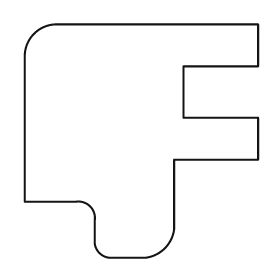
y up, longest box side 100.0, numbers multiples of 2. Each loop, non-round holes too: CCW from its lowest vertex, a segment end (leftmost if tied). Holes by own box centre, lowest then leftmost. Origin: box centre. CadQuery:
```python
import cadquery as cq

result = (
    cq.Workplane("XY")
    .moveTo(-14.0, -50.0)
    .lineTo(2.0, -50.0)
    .threePointArc((10.0, -46.0), (14.0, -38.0))
    .lineTo(14.0, -8.0)
    .lineTo(50.0, -8.0)
    .lineTo(50.0, 10.0)
    .lineTo(18.0, 10.0)
    .lineTo(18.0, 32.0)
    .lineTo(50.0, 32.0)
    .lineTo(50.0, 50.0)
    .lineTo(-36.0, 50.0)
    .threePointArc((-46.0, 46.0), (-50.0, 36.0))
    .lineTo(-50.0, -26.0)
    .lineTo(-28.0, -26.0)
    .threePointArc((-22.0, -28.0), (-20.0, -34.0))
    .lineTo(-20.0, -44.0)
    .threePointArc((-18.0, -48.0), (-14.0, -50.0))
    .close()
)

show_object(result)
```